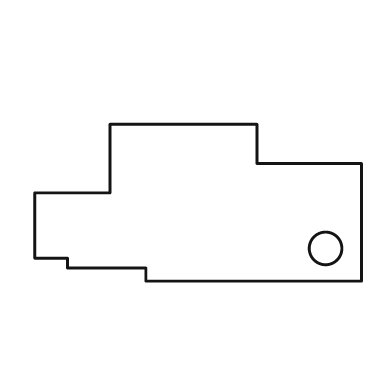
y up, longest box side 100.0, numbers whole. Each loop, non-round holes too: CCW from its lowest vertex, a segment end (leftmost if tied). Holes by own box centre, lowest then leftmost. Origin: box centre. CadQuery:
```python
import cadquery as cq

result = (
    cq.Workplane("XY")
    .moveTo(-16.0, -24.0)
    .lineTo(50.0, -24.0)
    .lineTo(50.0, 12.0)
    .lineTo(18.0, 12.0)
    .lineTo(18.0, 24.0)
    .lineTo(-27.0, 24.0)
    .lineTo(-27.0, 3.0)
    .lineTo(-50.0, 3.0)
    .lineTo(-50.0, -17.0)
    .lineTo(-40.0, -17.0)
    .lineTo(-40.0, -20.0)
    .lineTo(-16.0, -20.0)
    .close()
    .moveTo(39.0, -14.0)
    .circle(5.0)
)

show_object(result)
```